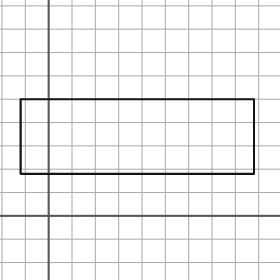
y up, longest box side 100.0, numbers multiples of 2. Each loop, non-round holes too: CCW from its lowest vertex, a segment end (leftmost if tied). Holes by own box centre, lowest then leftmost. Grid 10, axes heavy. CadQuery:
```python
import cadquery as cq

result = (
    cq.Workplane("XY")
    .moveTo(-12.0, 18.0)
    .lineTo(88.0, 18.0)
    .lineTo(88.0, 50.0)
    .lineTo(-12.0, 50.0)
    .close()
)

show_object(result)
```